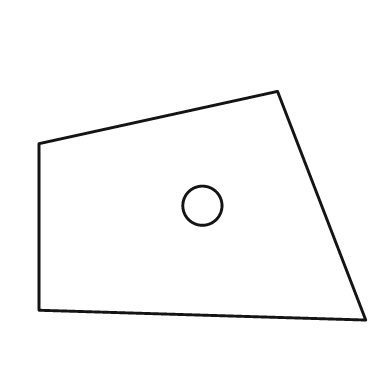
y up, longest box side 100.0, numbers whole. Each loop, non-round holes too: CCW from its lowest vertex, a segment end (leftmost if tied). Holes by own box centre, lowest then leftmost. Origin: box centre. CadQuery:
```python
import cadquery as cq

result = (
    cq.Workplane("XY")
    .moveTo(50.0, -35.0)
    .lineTo(23.0, 35.0)
    .lineTo(-50.0, 19.0)
    .lineTo(-50.0, -32.0)
    .close()
    .moveTo(0.0, 0.0)
    .circle(6.0)
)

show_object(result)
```